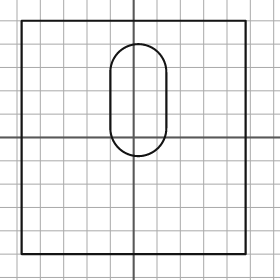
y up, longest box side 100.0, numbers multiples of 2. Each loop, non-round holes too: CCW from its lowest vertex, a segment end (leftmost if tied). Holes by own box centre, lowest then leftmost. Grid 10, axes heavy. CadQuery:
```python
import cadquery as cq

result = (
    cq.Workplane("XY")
    .moveTo(-48.0, -50.0)
    .lineTo(48.0, -50.0)
    .lineTo(48.0, 50.0)
    .lineTo(-48.0, 50.0)
    .close()
    .moveTo(-10.0, 4.0)
    .threePointArc((2.0, -8.0), (14.0, 4.0))
    .lineTo(14.0, 28.0)
    .threePointArc((2.0, 40.0), (-10.0, 28.0))
    .close()
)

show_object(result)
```